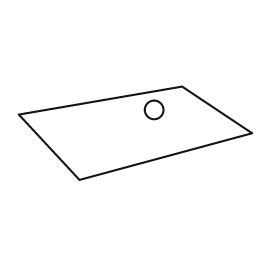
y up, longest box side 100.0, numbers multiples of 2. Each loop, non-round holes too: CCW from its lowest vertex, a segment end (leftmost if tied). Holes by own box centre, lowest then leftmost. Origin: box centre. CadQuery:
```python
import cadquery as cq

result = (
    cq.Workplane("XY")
    .moveTo(-24.0, -20.0)
    .lineTo(50.0, 0.0)
    .lineTo(20.0, 20.0)
    .lineTo(-50.0, 8.0)
    .close()
    .moveTo(8.0, 10.0)
    .circle(4.0)
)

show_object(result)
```